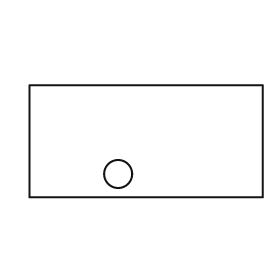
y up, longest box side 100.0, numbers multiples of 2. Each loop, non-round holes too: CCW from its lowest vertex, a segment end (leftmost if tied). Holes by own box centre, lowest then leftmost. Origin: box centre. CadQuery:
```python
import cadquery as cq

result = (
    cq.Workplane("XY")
    .moveTo(-50.0, -24.0)
    .lineTo(50.0, -24.0)
    .lineTo(50.0, 24.0)
    .lineTo(-50.0, 24.0)
    .close()
    .moveTo(-12.0, -14.0)
    .circle(6.0)
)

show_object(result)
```